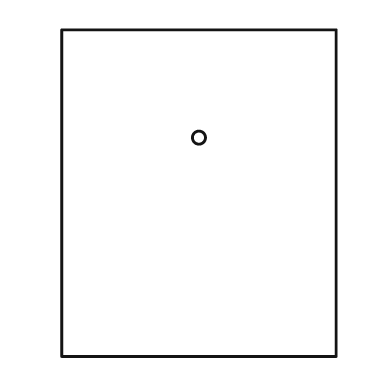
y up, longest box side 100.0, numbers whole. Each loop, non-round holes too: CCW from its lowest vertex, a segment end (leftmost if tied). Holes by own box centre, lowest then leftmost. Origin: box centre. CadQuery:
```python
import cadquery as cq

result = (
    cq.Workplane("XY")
    .moveTo(-42.0, -50.0)
    .lineTo(42.0, -50.0)
    .lineTo(42.0, 50.0)
    .lineTo(-42.0, 50.0)
    .close()
    .moveTo(0.0, 17.0)
    .circle(2.0)
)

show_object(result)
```